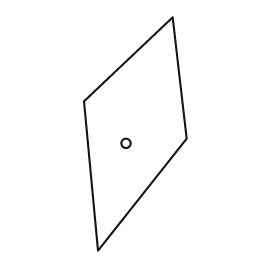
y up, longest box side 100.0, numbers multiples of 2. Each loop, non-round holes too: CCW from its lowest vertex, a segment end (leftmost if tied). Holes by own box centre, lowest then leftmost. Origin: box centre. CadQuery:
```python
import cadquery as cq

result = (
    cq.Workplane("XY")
    .moveTo(-16.0, -50.0)
    .lineTo(22.0, -2.0)
    .lineTo(16.0, 50.0)
    .lineTo(-22.0, 14.0)
    .close()
    .moveTo(-4.0, -4.0)
    .circle(2.0)
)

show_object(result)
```